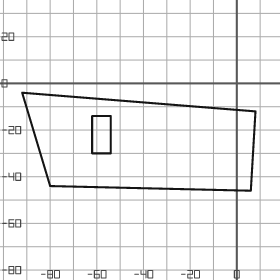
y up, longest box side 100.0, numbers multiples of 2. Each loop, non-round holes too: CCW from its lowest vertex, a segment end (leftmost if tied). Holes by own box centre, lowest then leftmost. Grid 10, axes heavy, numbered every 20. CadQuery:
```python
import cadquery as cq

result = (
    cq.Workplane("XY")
    .moveTo(6.0, -46.0)
    .lineTo(8.0, -12.0)
    .lineTo(-92.0, -4.0)
    .lineTo(-80.0, -44.0)
    .close()
    .moveTo(-62.0, -30.0)
    .lineTo(-54.0, -30.0)
    .lineTo(-54.0, -14.0)
    .lineTo(-62.0, -14.0)
    .close()
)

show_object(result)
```